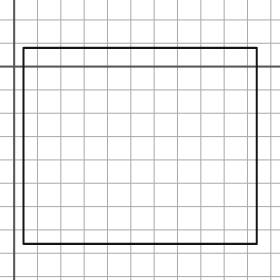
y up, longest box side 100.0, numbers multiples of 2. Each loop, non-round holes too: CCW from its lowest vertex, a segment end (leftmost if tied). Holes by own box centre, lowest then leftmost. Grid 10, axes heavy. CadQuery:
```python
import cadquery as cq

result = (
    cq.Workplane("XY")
    .moveTo(4.0, -76.0)
    .lineTo(104.0, -76.0)
    .lineTo(104.0, 8.0)
    .lineTo(4.0, 8.0)
    .close()
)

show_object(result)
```